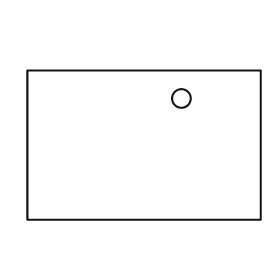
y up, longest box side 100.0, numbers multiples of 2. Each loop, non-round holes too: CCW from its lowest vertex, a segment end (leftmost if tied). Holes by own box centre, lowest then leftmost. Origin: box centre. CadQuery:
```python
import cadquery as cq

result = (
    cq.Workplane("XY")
    .moveTo(-50.0, -32.0)
    .lineTo(50.0, -32.0)
    .lineTo(50.0, 32.0)
    .lineTo(-50.0, 32.0)
    .close()
    .moveTo(16.0, 20.0)
    .circle(4.0)
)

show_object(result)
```